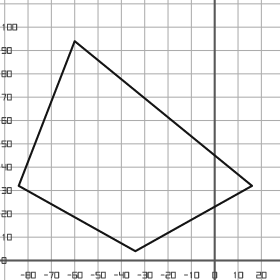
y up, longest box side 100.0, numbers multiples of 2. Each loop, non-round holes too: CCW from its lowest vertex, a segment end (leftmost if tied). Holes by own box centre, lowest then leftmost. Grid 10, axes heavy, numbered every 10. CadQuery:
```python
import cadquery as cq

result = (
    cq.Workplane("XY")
    .moveTo(-34.0, 4.0)
    .lineTo(16.0, 32.0)
    .lineTo(-60.0, 94.0)
    .lineTo(-84.0, 32.0)
    .close()
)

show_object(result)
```